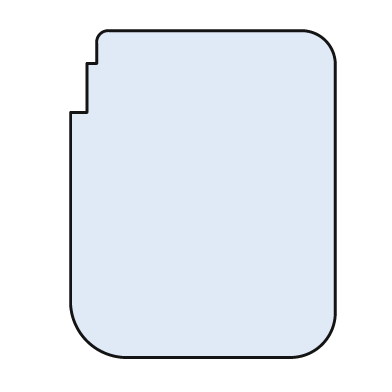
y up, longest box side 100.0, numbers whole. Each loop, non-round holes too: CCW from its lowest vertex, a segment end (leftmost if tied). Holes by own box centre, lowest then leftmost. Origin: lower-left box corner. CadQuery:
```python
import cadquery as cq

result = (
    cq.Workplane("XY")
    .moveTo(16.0, 0.0)
    .lineTo(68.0, 0.0)
    .threePointArc((77.0, 4.0), (81.0, 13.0))
    .lineTo(81.0, 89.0)
    .threePointArc((78.0, 97.0), (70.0, 100.0))
    .lineTo(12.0, 100.0)
    .threePointArc((9.0, 99.0), (8.0, 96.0))
    .lineTo(8.0, 90.0)
    .lineTo(5.0, 90.0)
    .lineTo(5.0, 75.0)
    .lineTo(0.0, 75.0)
    .lineTo(0.0, 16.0)
    .threePointArc((5.0, 5.0), (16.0, 0.0))
    .close()
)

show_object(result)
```